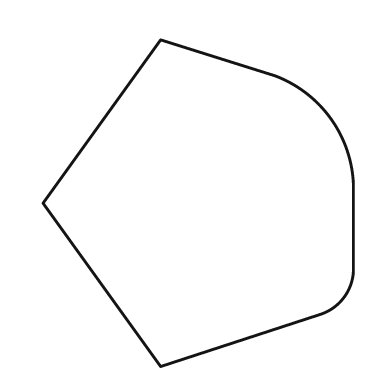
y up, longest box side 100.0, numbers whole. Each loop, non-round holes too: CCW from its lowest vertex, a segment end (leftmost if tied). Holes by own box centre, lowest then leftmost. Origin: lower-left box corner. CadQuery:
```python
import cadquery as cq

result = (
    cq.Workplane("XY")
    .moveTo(36.0, 0.0)
    .lineTo(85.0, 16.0)
    .threePointArc((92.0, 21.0), (95.0, 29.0))
    .lineTo(95.0, 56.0)
    .threePointArc((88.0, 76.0), (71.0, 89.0))
    .lineTo(36.0, 100.0)
    .lineTo(0.0, 50.0)
    .close()
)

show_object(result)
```